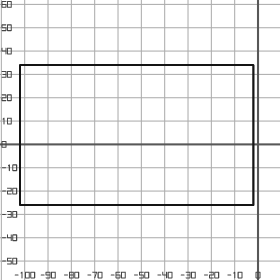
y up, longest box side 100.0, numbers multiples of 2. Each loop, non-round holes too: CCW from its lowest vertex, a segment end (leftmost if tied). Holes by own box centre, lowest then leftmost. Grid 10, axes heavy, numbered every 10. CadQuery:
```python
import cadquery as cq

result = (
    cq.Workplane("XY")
    .moveTo(-102.0, -26.0)
    .lineTo(-2.0, -26.0)
    .lineTo(-2.0, 34.0)
    .lineTo(-102.0, 34.0)
    .close()
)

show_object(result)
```